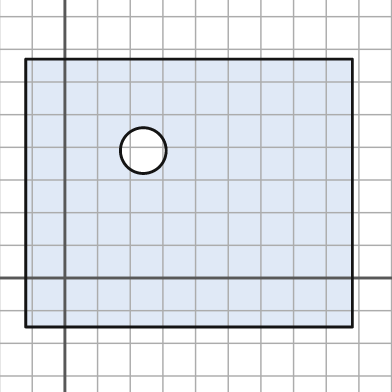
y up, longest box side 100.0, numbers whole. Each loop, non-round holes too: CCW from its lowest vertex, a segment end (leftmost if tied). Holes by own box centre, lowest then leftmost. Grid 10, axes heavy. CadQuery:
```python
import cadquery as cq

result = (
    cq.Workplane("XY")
    .moveTo(-12.0, -15.0)
    .lineTo(88.0, -15.0)
    .lineTo(88.0, 67.0)
    .lineTo(-12.0, 67.0)
    .close()
    .moveTo(24.0, 39.0)
    .circle(7.0)
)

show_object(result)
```